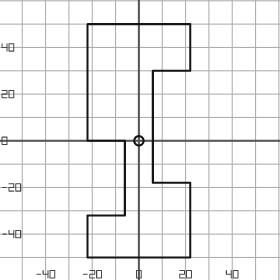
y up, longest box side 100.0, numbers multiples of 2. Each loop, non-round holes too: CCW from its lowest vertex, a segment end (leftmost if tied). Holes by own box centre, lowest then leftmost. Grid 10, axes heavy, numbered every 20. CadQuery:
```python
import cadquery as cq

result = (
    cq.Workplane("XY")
    .moveTo(-22.0, -50.0)
    .lineTo(22.0, -50.0)
    .lineTo(22.0, -18.0)
    .lineTo(6.0, -18.0)
    .lineTo(6.0, 30.0)
    .lineTo(22.0, 30.0)
    .lineTo(22.0, 50.0)
    .lineTo(-22.0, 50.0)
    .lineTo(-22.0, 0.0)
    .lineTo(-6.0, 0.0)
    .lineTo(-6.0, -32.0)
    .lineTo(-22.0, -32.0)
    .close()
    .moveTo(0.0, 0.0)
    .circle(2.0)
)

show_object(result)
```